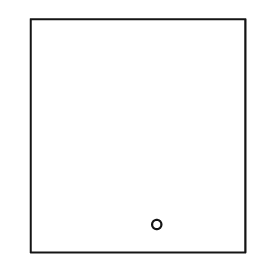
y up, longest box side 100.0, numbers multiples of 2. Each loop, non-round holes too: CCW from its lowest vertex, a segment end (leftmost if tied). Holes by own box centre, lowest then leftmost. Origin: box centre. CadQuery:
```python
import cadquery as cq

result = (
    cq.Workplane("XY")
    .moveTo(-46.0, -50.0)
    .lineTo(46.0, -50.0)
    .lineTo(46.0, 50.0)
    .lineTo(-46.0, 50.0)
    .close()
    .moveTo(8.0, -38.0)
    .circle(2.0)
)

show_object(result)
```